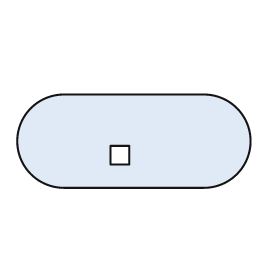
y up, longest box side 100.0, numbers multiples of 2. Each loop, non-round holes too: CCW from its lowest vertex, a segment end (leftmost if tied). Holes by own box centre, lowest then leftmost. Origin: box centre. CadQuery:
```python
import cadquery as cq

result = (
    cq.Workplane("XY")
    .moveTo(-30.0, -20.0)
    .lineTo(30.0, -20.0)
    .threePointArc((50.0, 0.0), (30.0, 20.0))
    .lineTo(-30.0, 20.0)
    .threePointArc((-50.0, 0.0), (-30.0, -20.0))
    .close()
    .moveTo(-10.0, -10.0)
    .lineTo(-2.0, -10.0)
    .lineTo(-2.0, -2.0)
    .lineTo(-10.0, -2.0)
    .close()
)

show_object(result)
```